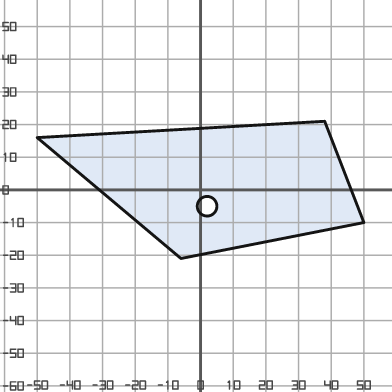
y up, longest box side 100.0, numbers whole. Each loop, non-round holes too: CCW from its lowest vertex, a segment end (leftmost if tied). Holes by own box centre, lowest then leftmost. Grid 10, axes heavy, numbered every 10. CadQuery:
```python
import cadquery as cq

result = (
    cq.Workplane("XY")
    .moveTo(-6.0, -21.0)
    .lineTo(50.0, -10.0)
    .lineTo(38.0, 21.0)
    .lineTo(-50.0, 16.0)
    .close()
    .moveTo(2.0, -5.0)
    .circle(3.0)
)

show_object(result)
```